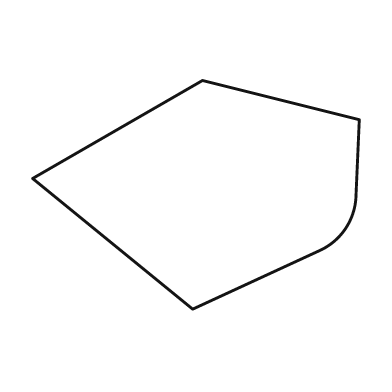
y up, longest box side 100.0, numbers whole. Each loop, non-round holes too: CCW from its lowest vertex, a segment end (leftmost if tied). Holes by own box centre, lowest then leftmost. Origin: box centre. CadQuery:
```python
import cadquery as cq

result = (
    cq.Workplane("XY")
    .moveTo(-1.0, -35.0)
    .lineTo(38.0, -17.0)
    .threePointArc((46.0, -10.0), (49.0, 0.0))
    .lineTo(50.0, 23.0)
    .lineTo(2.0, 35.0)
    .lineTo(-50.0, 5.0)
    .close()
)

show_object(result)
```